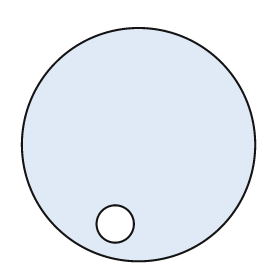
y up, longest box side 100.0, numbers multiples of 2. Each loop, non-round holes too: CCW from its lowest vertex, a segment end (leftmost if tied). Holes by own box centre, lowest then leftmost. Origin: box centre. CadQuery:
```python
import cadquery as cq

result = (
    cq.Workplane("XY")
    .moveTo(0.0, 0.0)
    .circle(50.0)
    .moveTo(-10.0, -34.0)
    .circle(8.0)
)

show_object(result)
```